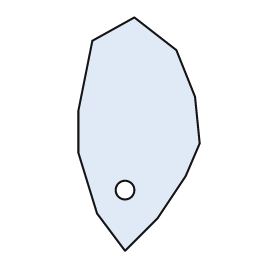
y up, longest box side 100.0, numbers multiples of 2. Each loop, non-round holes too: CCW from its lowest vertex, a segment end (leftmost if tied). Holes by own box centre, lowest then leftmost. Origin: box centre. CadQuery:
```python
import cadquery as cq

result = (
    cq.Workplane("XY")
    .moveTo(-6.0, -50.0)
    .lineTo(8.0, -36.0)
    .lineTo(20.0, -18.0)
    .lineTo(26.0, -4.0)
    .lineTo(24.0, 16.0)
    .lineTo(16.0, 36.0)
    .lineTo(-2.0, 50.0)
    .lineTo(-20.0, 40.0)
    .lineTo(-26.0, 10.0)
    .lineTo(-26.0, -8.0)
    .lineTo(-18.0, -34.0)
    .close()
    .moveTo(-6.0, -24.0)
    .circle(4.0)
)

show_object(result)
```